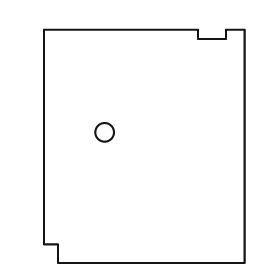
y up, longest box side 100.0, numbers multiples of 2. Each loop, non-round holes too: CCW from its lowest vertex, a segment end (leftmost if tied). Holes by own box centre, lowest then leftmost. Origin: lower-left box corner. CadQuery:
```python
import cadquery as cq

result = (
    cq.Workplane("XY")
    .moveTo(6.0, 0.0)
    .lineTo(86.0, 0.0)
    .lineTo(86.0, 100.0)
    .lineTo(78.0, 100.0)
    .lineTo(78.0, 96.0)
    .lineTo(66.0, 96.0)
    .lineTo(66.0, 100.0)
    .lineTo(0.0, 100.0)
    .lineTo(0.0, 8.0)
    .lineTo(6.0, 8.0)
    .close()
    .moveTo(26.0, 56.0)
    .circle(4.0)
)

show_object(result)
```